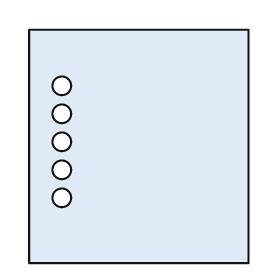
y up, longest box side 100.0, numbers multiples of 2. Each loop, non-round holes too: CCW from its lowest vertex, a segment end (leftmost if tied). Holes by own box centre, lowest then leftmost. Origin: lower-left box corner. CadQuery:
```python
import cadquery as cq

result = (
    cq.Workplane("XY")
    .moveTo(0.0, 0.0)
    .lineTo(94.0, 0.0)
    .lineTo(94.0, 100.0)
    .lineTo(0.0, 100.0)
    .close()
    .moveTo(14.0, 28.0)
    .circle(4.0)
    .moveTo(14.0, 40.0)
    .circle(4.0)
    .moveTo(14.0, 52.0)
    .circle(4.0)
    .moveTo(14.0, 64.0)
    .circle(4.0)
    .moveTo(14.0, 76.0)
    .circle(4.0)
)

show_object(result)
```